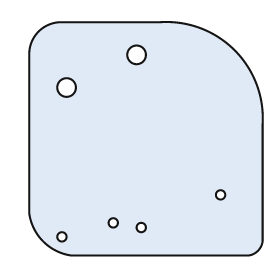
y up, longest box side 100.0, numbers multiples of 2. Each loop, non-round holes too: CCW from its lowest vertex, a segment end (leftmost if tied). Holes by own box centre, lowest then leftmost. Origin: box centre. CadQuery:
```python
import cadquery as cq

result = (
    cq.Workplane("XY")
    .moveTo(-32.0, -50.0)
    .lineTo(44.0, -50.0)
    .threePointArc((48.0, -48.0), (50.0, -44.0))
    .lineTo(50.0, 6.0)
    .threePointArc((38.0, 38.0), (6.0, 50.0))
    .lineTo(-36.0, 50.0)
    .threePointArc((-46.0, 46.0), (-50.0, 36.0))
    .lineTo(-50.0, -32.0)
    .threePointArc((-44.0, -44.0), (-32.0, -50.0))
    .close()
    .moveTo(-36.0, -42.0)
    .circle(2.0)
    .moveTo(-2.0, -38.0)
    .circle(2.0)
    .moveTo(-14.0, -36.0)
    .circle(2.0)
    .moveTo(32.0, -24.0)
    .circle(2.0)
    .moveTo(-34.0, 22.0)
    .circle(4.0)
    .moveTo(-4.0, 36.0)
    .circle(4.0)
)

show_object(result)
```